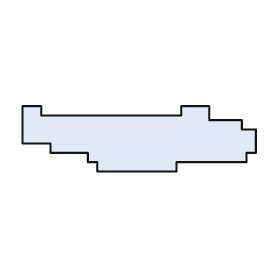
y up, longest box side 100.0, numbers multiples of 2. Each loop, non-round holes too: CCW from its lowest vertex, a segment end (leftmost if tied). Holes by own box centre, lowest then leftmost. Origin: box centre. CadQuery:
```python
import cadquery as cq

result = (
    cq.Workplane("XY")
    .moveTo(-18.0, -14.0)
    .lineTo(16.0, -14.0)
    .lineTo(16.0, -10.0)
    .lineTo(46.0, -10.0)
    .lineTo(46.0, -6.0)
    .lineTo(50.0, -6.0)
    .lineTo(50.0, 4.0)
    .lineTo(44.0, 4.0)
    .lineTo(44.0, 8.0)
    .lineTo(30.0, 8.0)
    .lineTo(30.0, 14.0)
    .lineTo(18.0, 14.0)
    .lineTo(18.0, 10.0)
    .lineTo(-42.0, 10.0)
    .lineTo(-42.0, 14.0)
    .lineTo(-50.0, 14.0)
    .lineTo(-50.0, -2.0)
    .lineTo(-38.0, -2.0)
    .lineTo(-38.0, -6.0)
    .lineTo(-22.0, -6.0)
    .lineTo(-22.0, -10.0)
    .lineTo(-18.0, -10.0)
    .close()
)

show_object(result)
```